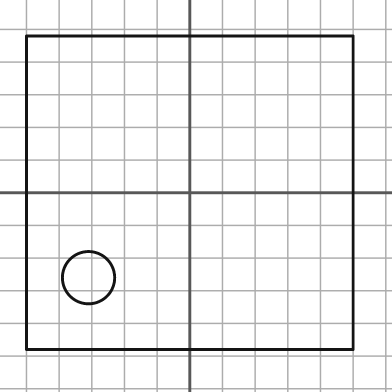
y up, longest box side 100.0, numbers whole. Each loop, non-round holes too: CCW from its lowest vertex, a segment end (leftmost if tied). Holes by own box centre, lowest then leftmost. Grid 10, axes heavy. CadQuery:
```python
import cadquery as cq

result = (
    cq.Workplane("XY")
    .moveTo(-50.0, -48.0)
    .lineTo(50.0, -48.0)
    .lineTo(50.0, 48.0)
    .lineTo(-50.0, 48.0)
    .close()
    .moveTo(-31.0, -26.0)
    .circle(8.0)
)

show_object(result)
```